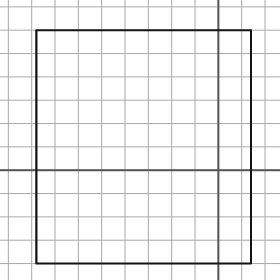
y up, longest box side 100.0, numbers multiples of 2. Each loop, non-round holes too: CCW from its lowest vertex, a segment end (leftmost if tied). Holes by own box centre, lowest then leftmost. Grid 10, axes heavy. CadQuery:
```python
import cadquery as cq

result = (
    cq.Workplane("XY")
    .moveTo(-78.0, -40.0)
    .lineTo(14.0, -40.0)
    .lineTo(14.0, 60.0)
    .lineTo(-78.0, 60.0)
    .close()
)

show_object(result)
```